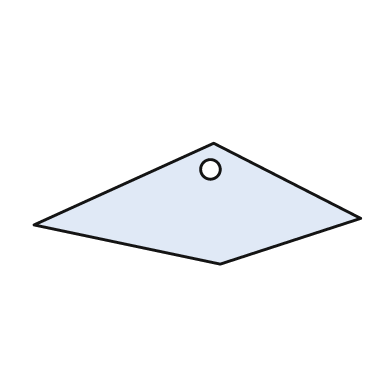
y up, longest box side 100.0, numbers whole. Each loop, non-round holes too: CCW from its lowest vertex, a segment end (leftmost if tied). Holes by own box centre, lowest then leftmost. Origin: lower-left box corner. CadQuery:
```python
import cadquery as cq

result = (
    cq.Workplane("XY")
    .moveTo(57.0, 0.0)
    .lineTo(100.0, 14.0)
    .lineTo(55.0, 37.0)
    .lineTo(0.0, 12.0)
    .close()
    .moveTo(54.0, 29.0)
    .circle(3.0)
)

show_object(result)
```